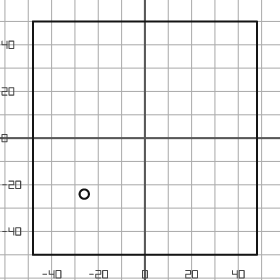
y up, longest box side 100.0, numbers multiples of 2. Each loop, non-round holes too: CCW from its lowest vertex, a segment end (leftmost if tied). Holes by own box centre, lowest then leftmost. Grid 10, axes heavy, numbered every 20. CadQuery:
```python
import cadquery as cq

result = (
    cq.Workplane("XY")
    .moveTo(-48.0, -50.0)
    .lineTo(48.0, -50.0)
    .lineTo(48.0, 50.0)
    .lineTo(-48.0, 50.0)
    .close()
    .moveTo(-26.0, -24.0)
    .circle(2.0)
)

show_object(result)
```